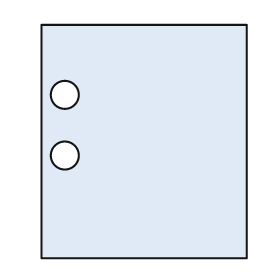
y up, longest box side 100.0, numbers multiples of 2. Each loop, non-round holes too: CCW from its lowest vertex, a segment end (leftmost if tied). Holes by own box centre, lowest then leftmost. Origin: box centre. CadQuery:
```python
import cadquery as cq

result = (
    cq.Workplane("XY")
    .moveTo(-44.0, -50.0)
    .lineTo(44.0, -50.0)
    .lineTo(44.0, 50.0)
    .lineTo(-44.0, 50.0)
    .close()
    .moveTo(-34.0, -6.0)
    .circle(6.0)
    .moveTo(-34.0, 20.0)
    .circle(6.0)
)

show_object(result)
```